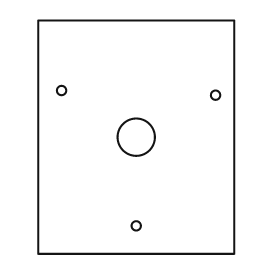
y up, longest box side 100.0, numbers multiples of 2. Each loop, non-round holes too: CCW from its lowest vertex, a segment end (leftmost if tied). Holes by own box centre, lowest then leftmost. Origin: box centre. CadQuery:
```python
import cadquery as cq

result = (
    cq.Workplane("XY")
    .moveTo(-42.0, -50.0)
    .lineTo(42.0, -50.0)
    .lineTo(42.0, 50.0)
    .lineTo(-42.0, 50.0)
    .close()
    .moveTo(0.0, -38.0)
    .circle(2.0)
    .moveTo(0.0, 0.0)
    .circle(8.0)
    .moveTo(34.0, 18.0)
    .circle(2.0)
    .moveTo(-32.0, 20.0)
    .circle(2.0)
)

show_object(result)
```